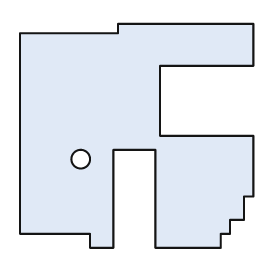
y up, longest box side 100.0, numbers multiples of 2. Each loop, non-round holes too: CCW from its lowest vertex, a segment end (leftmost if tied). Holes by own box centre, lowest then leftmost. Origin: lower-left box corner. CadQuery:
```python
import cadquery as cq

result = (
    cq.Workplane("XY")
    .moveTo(30.0, 0.0)
    .lineTo(40.0, 0.0)
    .lineTo(40.0, 42.0)
    .lineTo(58.0, 42.0)
    .lineTo(58.0, 0.0)
    .lineTo(86.0, 0.0)
    .lineTo(86.0, 6.0)
    .lineTo(90.0, 6.0)
    .lineTo(90.0, 12.0)
    .lineTo(96.0, 12.0)
    .lineTo(96.0, 22.0)
    .lineTo(100.0, 22.0)
    .lineTo(100.0, 48.0)
    .lineTo(60.0, 48.0)
    .lineTo(60.0, 78.0)
    .lineTo(100.0, 78.0)
    .lineTo(100.0, 96.0)
    .lineTo(42.0, 96.0)
    .lineTo(42.0, 92.0)
    .lineTo(0.0, 92.0)
    .lineTo(0.0, 6.0)
    .lineTo(30.0, 6.0)
    .close()
    .moveTo(26.0, 38.0)
    .circle(4.0)
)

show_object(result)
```